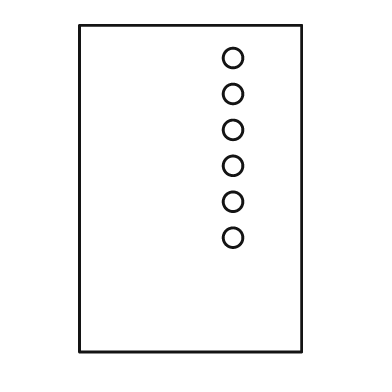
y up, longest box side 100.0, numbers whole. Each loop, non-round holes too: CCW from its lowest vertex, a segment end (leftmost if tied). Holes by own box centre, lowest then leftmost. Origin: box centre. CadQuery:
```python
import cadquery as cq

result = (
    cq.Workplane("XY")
    .moveTo(-34.0, -50.0)
    .lineTo(34.0, -50.0)
    .lineTo(34.0, 50.0)
    .lineTo(-34.0, 50.0)
    .close()
    .moveTo(13.0, -15.0)
    .circle(3.0)
    .moveTo(13.0, -4.0)
    .circle(3.0)
    .moveTo(13.0, 7.0)
    .circle(3.0)
    .moveTo(13.0, 18.0)
    .circle(3.0)
    .moveTo(13.0, 29.0)
    .circle(3.0)
    .moveTo(13.0, 40.0)
    .circle(3.0)
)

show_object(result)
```